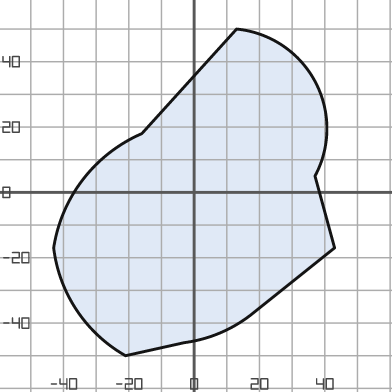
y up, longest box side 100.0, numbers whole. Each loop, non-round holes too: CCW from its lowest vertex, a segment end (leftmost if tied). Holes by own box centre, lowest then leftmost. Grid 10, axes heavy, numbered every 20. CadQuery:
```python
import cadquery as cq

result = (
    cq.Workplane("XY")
    .moveTo(-21.0, -50.0)
    .lineTo(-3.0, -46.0)
    .threePointArc((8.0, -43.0), (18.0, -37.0))
    .lineTo(43.0, -17.0)
    .lineTo(37.0, 5.0)
    .threePointArc((37.0, 34.0), (13.0, 50.0))
    .lineTo(-16.0, 18.0)
    .threePointArc((-34.0, 4.0), (-43.0, -17.0))
    .threePointArc((-36.0, -36.0), (-21.0, -50.0))
    .close()
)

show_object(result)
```